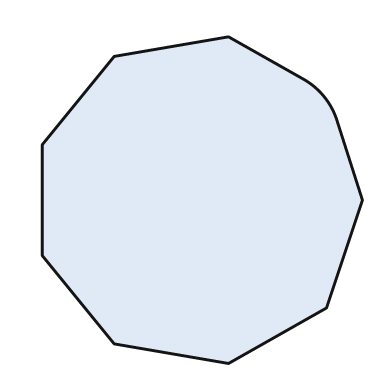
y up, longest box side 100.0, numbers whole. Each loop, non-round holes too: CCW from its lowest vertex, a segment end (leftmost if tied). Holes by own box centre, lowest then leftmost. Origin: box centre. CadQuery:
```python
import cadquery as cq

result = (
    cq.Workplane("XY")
    .moveTo(8.0, -50.0)
    .lineTo(38.0, -33.0)
    .lineTo(49.0, 0.0)
    .lineTo(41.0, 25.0)
    .threePointArc((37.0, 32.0), (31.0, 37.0))
    .lineTo(8.0, 50.0)
    .lineTo(-27.0, 44.0)
    .lineTo(-49.0, 17.0)
    .lineTo(-49.0, -17.0)
    .lineTo(-27.0, -44.0)
    .close()
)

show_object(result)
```